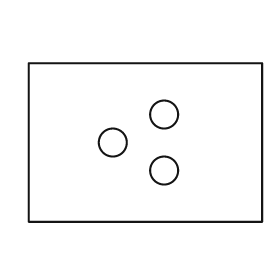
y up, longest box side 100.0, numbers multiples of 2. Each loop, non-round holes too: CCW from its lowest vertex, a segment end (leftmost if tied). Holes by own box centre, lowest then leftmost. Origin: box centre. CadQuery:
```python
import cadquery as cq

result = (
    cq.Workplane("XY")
    .moveTo(-50.0, -34.0)
    .lineTo(50.0, -34.0)
    .lineTo(50.0, 34.0)
    .lineTo(-50.0, 34.0)
    .close()
    .moveTo(8.0, -12.0)
    .circle(6.0)
    .moveTo(-14.0, 0.0)
    .circle(6.0)
    .moveTo(8.0, 12.0)
    .circle(6.0)
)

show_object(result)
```